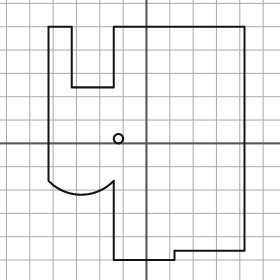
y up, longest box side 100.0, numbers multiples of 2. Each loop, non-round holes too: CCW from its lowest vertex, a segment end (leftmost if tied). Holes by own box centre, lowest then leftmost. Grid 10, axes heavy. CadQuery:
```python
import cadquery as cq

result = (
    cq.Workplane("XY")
    .moveTo(-14.0, -50.0)
    .lineTo(12.0, -50.0)
    .lineTo(12.0, -46.0)
    .lineTo(42.0, -46.0)
    .lineTo(42.0, 50.0)
    .lineTo(-14.0, 50.0)
    .lineTo(-14.0, 24.0)
    .lineTo(-32.0, 24.0)
    .lineTo(-32.0, 50.0)
    .lineTo(-42.0, 50.0)
    .lineTo(-42.0, -16.0)
    .threePointArc((-28.0, -22.0), (-14.0, -16.0))
    .close()
    .moveTo(-12.0, 2.0)
    .circle(2.0)
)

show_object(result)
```